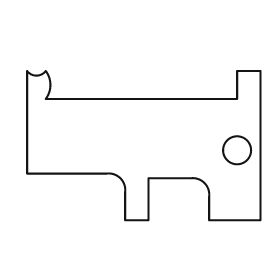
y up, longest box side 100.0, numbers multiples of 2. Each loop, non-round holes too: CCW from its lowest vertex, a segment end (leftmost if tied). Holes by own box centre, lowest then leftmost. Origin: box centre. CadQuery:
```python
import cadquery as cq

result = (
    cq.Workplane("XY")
    .moveTo(-8.0, -32.0)
    .lineTo(2.0, -32.0)
    .lineTo(2.0, -14.0)
    .lineTo(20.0, -14.0)
    .threePointArc((26.0, -16.0), (28.0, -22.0))
    .lineTo(28.0, -32.0)
    .lineTo(50.0, -32.0)
    .lineTo(50.0, 32.0)
    .lineTo(40.0, 32.0)
    .lineTo(40.0, 20.0)
    .lineTo(-42.0, 20.0)
    .threePointArc((-40.0, 26.0), (-42.0, 32.0))
    .threePointArc((-46.0, 30.0), (-50.0, 32.0))
    .lineTo(-50.0, -12.0)
    .lineTo(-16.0, -12.0)
    .threePointArc((-10.0, -14.0), (-8.0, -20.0))
    .close()
    .moveTo(40.0, -2.0)
    .circle(6.0)
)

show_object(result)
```